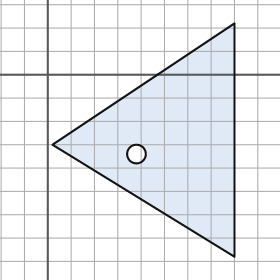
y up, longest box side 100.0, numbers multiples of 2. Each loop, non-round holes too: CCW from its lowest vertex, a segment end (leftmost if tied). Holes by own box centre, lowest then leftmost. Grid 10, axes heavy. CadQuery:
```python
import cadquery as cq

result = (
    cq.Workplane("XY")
    .moveTo(80.0, -78.0)
    .lineTo(80.0, 22.0)
    .lineTo(2.0, -30.0)
    .close()
    .moveTo(38.0, -34.0)
    .circle(4.0)
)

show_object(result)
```